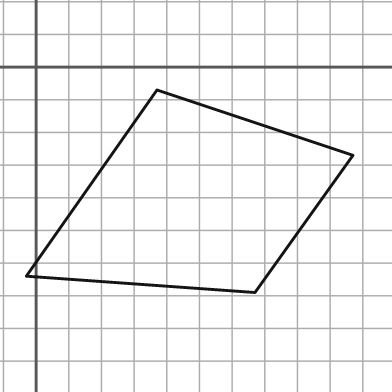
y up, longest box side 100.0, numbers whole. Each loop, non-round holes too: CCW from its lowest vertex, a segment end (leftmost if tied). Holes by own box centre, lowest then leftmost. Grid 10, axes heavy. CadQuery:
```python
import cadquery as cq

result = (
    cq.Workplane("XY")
    .moveTo(67.0, -69.0)
    .lineTo(97.0, -27.0)
    .lineTo(37.0, -7.0)
    .lineTo(-3.0, -64.0)
    .close()
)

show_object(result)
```